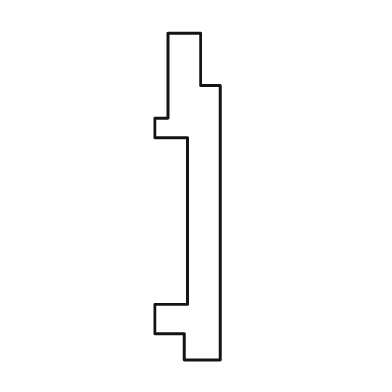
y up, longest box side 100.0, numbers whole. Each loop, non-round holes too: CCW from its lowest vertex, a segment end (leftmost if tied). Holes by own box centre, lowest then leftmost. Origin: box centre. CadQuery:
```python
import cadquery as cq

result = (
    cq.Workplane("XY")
    .moveTo(-1.0, -50.0)
    .lineTo(10.0, -50.0)
    .lineTo(10.0, 34.0)
    .lineTo(4.0, 34.0)
    .lineTo(4.0, 50.0)
    .lineTo(-6.0, 50.0)
    .lineTo(-6.0, 24.0)
    .lineTo(-10.0, 24.0)
    .lineTo(-10.0, 18.0)
    .lineTo(0.0, 18.0)
    .lineTo(0.0, -33.0)
    .lineTo(-10.0, -33.0)
    .lineTo(-10.0, -42.0)
    .lineTo(-1.0, -42.0)
    .close()
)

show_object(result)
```